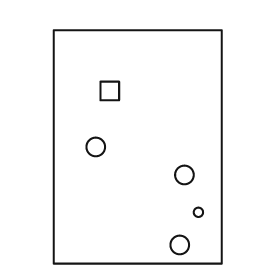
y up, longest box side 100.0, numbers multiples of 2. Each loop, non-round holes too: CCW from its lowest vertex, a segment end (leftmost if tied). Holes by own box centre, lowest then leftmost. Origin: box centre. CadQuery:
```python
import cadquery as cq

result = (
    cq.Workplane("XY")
    .moveTo(-36.0, -50.0)
    .lineTo(36.0, -50.0)
    .lineTo(36.0, 50.0)
    .lineTo(-36.0, 50.0)
    .close()
    .moveTo(18.0, -42.0)
    .circle(4.0)
    .moveTo(26.0, -28.0)
    .circle(2.0)
    .moveTo(20.0, -12.0)
    .circle(4.0)
    .moveTo(-18.0, 0.0)
    .circle(4.0)
    .moveTo(-16.0, 20.0)
    .lineTo(-8.0, 20.0)
    .lineTo(-8.0, 28.0)
    .lineTo(-16.0, 28.0)
    .close()
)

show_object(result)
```